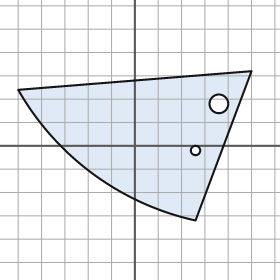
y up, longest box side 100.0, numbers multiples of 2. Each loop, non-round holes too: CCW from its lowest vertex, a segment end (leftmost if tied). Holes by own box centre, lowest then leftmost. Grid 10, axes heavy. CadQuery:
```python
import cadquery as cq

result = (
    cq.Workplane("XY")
    .moveTo(26.0, -32.0)
    .lineTo(50.0, 32.0)
    .lineTo(-50.0, 24.0)
    .threePointArc((-18.0, -12.0), (26.0, -32.0))
    .close()
    .moveTo(26.0, -2.0)
    .circle(2.0)
    .moveTo(36.0, 18.0)
    .circle(4.0)
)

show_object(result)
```